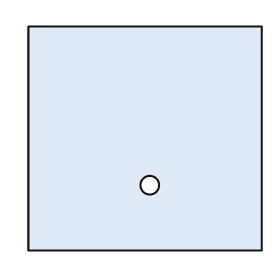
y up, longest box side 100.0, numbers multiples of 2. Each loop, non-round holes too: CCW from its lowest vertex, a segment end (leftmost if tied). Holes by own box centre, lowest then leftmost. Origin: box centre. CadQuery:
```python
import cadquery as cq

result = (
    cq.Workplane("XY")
    .moveTo(-50.0, -48.0)
    .lineTo(50.0, -48.0)
    .lineTo(50.0, 48.0)
    .lineTo(-50.0, 48.0)
    .close()
    .moveTo(2.0, -20.0)
    .circle(4.0)
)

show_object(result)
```